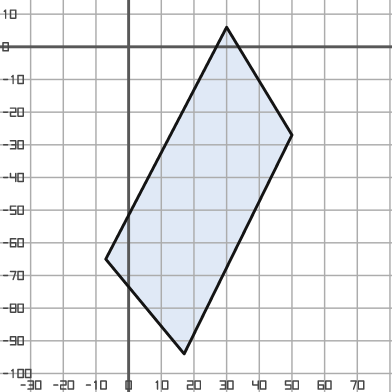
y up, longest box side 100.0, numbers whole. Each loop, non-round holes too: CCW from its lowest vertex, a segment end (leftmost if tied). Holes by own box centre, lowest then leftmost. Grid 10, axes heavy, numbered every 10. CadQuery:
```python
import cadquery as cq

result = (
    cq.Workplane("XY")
    .moveTo(17.0, -94.0)
    .lineTo(50.0, -27.0)
    .lineTo(30.0, 6.0)
    .lineTo(-7.0, -65.0)
    .close()
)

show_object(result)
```